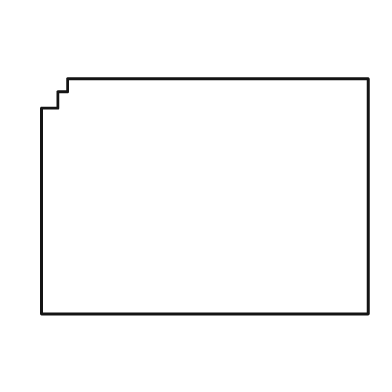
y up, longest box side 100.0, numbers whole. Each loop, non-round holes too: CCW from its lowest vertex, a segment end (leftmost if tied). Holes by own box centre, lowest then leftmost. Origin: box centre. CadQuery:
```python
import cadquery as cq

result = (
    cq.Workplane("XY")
    .moveTo(-50.0, -36.0)
    .lineTo(50.0, -36.0)
    .lineTo(50.0, 36.0)
    .lineTo(-42.0, 36.0)
    .lineTo(-42.0, 32.0)
    .lineTo(-45.0, 32.0)
    .lineTo(-45.0, 27.0)
    .lineTo(-50.0, 27.0)
    .close()
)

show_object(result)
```